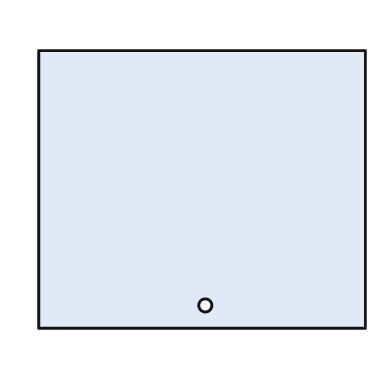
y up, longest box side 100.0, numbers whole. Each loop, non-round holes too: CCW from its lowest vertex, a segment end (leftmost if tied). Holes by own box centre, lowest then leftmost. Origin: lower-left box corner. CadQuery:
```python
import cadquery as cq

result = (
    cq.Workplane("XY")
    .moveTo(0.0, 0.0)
    .lineTo(100.0, 0.0)
    .lineTo(100.0, 85.0)
    .lineTo(0.0, 85.0)
    .close()
    .moveTo(51.0, 7.0)
    .circle(2.0)
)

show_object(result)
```